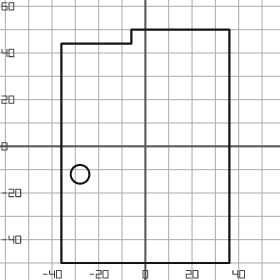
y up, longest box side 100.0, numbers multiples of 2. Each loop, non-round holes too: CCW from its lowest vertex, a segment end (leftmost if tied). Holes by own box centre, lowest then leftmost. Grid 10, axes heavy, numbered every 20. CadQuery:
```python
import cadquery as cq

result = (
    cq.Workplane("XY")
    .moveTo(-36.0, -50.0)
    .lineTo(36.0, -50.0)
    .lineTo(36.0, 50.0)
    .lineTo(-6.0, 50.0)
    .lineTo(-6.0, 44.0)
    .lineTo(-36.0, 44.0)
    .close()
    .moveTo(-28.0, -12.0)
    .circle(4.0)
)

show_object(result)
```